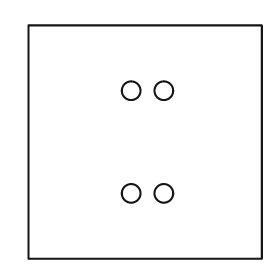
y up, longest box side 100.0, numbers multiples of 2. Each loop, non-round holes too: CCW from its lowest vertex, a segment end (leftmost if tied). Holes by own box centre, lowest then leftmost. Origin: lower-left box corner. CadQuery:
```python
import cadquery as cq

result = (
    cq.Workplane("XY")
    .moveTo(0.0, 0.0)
    .lineTo(100.0, 0.0)
    .lineTo(100.0, 100.0)
    .lineTo(0.0, 100.0)
    .close()
    .moveTo(44.0, 28.0)
    .circle(4.0)
    .moveTo(58.0, 28.0)
    .circle(4.0)
    .moveTo(44.0, 72.0)
    .circle(4.0)
    .moveTo(58.0, 72.0)
    .circle(4.0)
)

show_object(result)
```